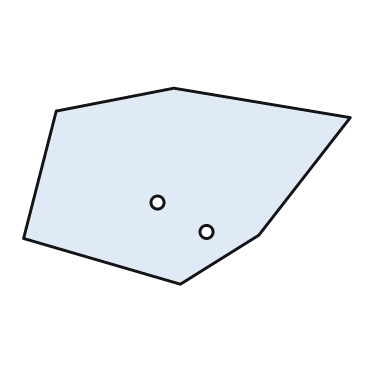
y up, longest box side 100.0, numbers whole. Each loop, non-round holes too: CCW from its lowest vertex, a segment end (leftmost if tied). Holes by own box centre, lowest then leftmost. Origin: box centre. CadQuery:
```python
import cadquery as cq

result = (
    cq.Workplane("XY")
    .moveTo(-2.0, -30.0)
    .lineTo(22.0, -15.0)
    .lineTo(50.0, 21.0)
    .lineTo(-4.0, 30.0)
    .lineTo(-40.0, 23.0)
    .lineTo(-50.0, -16.0)
    .close()
    .moveTo(6.0, -14.0)
    .circle(2.0)
    .moveTo(-9.0, -5.0)
    .circle(2.0)
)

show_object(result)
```